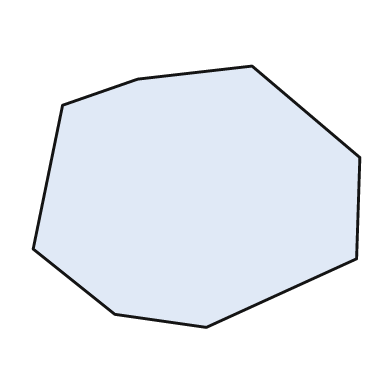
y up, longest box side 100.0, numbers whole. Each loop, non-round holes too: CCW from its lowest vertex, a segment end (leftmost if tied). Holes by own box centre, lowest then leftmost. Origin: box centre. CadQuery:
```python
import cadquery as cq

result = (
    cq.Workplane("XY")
    .moveTo(3.0, -40.0)
    .lineTo(49.0, -19.0)
    .lineTo(50.0, 12.0)
    .lineTo(17.0, 40.0)
    .lineTo(-18.0, 36.0)
    .lineTo(-41.0, 28.0)
    .lineTo(-50.0, -16.0)
    .lineTo(-25.0, -36.0)
    .close()
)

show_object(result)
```